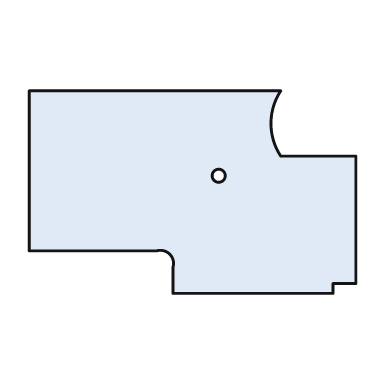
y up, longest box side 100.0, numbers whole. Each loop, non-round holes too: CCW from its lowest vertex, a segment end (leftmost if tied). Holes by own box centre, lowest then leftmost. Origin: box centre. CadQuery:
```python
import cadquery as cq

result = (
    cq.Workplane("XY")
    .moveTo(-6.0, -31.0)
    .lineTo(43.0, -31.0)
    .lineTo(43.0, -28.0)
    .lineTo(50.0, -28.0)
    .lineTo(50.0, 11.0)
    .lineTo(27.0, 11.0)
    .threePointArc((24.0, 21.0), (27.0, 31.0))
    .lineTo(-50.0, 31.0)
    .lineTo(-50.0, -18.0)
    .lineTo(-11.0, -18.0)
    .threePointArc((-7.0, -19.0), (-6.0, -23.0))
    .close()
    .moveTo(8.0, 5.0)
    .circle(2.0)
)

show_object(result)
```